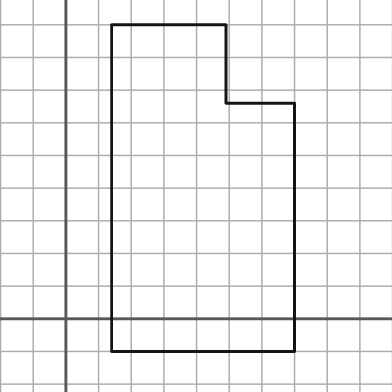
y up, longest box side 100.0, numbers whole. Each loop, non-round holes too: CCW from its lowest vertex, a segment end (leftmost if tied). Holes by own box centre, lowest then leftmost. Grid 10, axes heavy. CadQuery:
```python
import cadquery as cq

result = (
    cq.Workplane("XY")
    .moveTo(14.0, -10.0)
    .lineTo(70.0, -10.0)
    .lineTo(70.0, 66.0)
    .lineTo(49.0, 66.0)
    .lineTo(49.0, 90.0)
    .lineTo(14.0, 90.0)
    .close()
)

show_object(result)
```